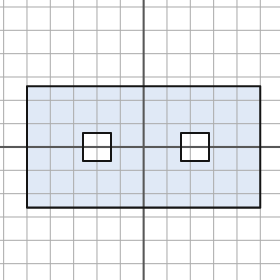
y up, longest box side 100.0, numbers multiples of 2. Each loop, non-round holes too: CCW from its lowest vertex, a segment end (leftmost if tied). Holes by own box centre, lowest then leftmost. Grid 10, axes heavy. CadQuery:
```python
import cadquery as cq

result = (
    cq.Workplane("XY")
    .moveTo(-50.0, -26.0)
    .lineTo(50.0, -26.0)
    .lineTo(50.0, 26.0)
    .lineTo(-50.0, 26.0)
    .close()
    .moveTo(-26.0, -6.0)
    .lineTo(-14.0, -6.0)
    .lineTo(-14.0, 6.0)
    .lineTo(-26.0, 6.0)
    .close()
    .moveTo(16.0, -6.0)
    .lineTo(28.0, -6.0)
    .lineTo(28.0, 6.0)
    .lineTo(16.0, 6.0)
    .close()
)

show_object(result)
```